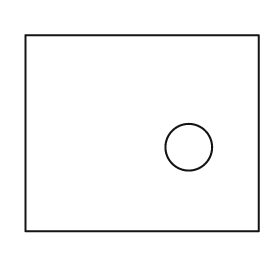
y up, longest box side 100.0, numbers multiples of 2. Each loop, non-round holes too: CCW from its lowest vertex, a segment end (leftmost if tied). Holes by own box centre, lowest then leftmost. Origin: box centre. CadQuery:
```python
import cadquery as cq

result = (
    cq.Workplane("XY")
    .moveTo(-50.0, -42.0)
    .lineTo(50.0, -42.0)
    .lineTo(50.0, 42.0)
    .lineTo(-50.0, 42.0)
    .close()
    .moveTo(20.0, -6.0)
    .circle(10.0)
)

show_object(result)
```